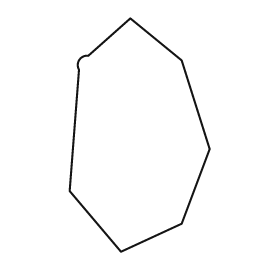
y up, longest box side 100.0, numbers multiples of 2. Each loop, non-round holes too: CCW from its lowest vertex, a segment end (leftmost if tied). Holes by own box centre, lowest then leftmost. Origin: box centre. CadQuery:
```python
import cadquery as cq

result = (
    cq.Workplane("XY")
    .moveTo(-8.0, -50.0)
    .lineTo(18.0, -38.0)
    .lineTo(30.0, -6.0)
    .lineTo(18.0, 32.0)
    .lineTo(-4.0, 50.0)
    .lineTo(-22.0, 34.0)
    .threePointArc((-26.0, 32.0), (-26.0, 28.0))
    .lineTo(-30.0, -24.0)
    .close()
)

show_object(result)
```